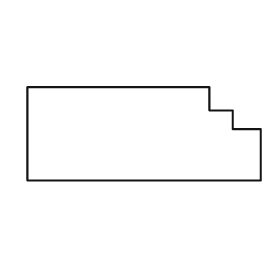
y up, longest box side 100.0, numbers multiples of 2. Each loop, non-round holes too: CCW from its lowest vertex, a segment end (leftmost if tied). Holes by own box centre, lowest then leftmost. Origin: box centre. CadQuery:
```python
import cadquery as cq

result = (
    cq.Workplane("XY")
    .moveTo(-50.0, -20.0)
    .lineTo(50.0, -20.0)
    .lineTo(50.0, 2.0)
    .lineTo(38.0, 2.0)
    .lineTo(38.0, 10.0)
    .lineTo(28.0, 10.0)
    .lineTo(28.0, 20.0)
    .lineTo(-50.0, 20.0)
    .close()
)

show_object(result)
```